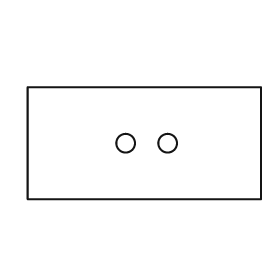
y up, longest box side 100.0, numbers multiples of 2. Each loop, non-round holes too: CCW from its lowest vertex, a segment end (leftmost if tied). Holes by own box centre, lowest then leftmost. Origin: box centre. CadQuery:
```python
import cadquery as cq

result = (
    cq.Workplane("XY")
    .moveTo(-50.0, -24.0)
    .lineTo(50.0, -24.0)
    .lineTo(50.0, 24.0)
    .lineTo(-50.0, 24.0)
    .close()
    .moveTo(-8.0, 0.0)
    .circle(4.0)
    .moveTo(10.0, 0.0)
    .circle(4.0)
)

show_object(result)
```